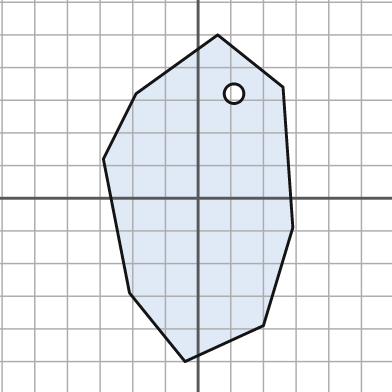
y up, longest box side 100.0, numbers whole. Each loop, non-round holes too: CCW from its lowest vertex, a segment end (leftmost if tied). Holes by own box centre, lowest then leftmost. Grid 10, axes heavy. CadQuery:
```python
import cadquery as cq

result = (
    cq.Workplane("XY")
    .moveTo(-4.0, -50.0)
    .lineTo(20.0, -39.0)
    .lineTo(29.0, -9.0)
    .lineTo(26.0, 34.0)
    .lineTo(6.0, 50.0)
    .lineTo(-19.0, 32.0)
    .lineTo(-29.0, 12.0)
    .lineTo(-21.0, -29.0)
    .close()
    .moveTo(11.0, 32.0)
    .circle(3.0)
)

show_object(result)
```